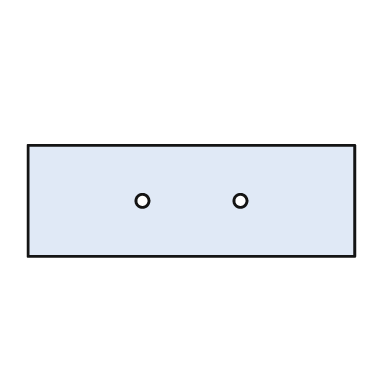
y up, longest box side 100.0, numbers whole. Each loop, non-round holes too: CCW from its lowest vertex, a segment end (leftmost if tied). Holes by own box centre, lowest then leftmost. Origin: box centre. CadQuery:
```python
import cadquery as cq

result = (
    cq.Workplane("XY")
    .moveTo(-50.0, -17.0)
    .lineTo(50.0, -17.0)
    .lineTo(50.0, 17.0)
    .lineTo(-50.0, 17.0)
    .close()
    .moveTo(-15.0, 0.0)
    .circle(2.0)
    .moveTo(15.0, 0.0)
    .circle(2.0)
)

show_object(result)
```